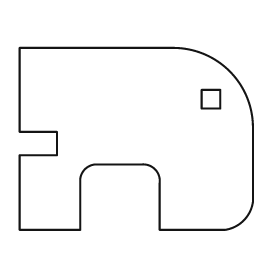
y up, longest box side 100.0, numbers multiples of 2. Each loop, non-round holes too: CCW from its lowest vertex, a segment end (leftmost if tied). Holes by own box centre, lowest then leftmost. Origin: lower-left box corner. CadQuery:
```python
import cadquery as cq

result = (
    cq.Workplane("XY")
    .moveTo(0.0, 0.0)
    .lineTo(26.0, 0.0)
    .lineTo(26.0, 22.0)
    .threePointArc((28.0, 26.0), (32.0, 28.0))
    .lineTo(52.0, 28.0)
    .threePointArc((58.0, 26.0), (60.0, 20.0))
    .lineTo(60.0, 0.0)
    .lineTo(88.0, 0.0)
    .threePointArc((96.0, 4.0), (100.0, 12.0))
    .lineTo(100.0, 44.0)
    .threePointArc((90.0, 68.0), (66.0, 78.0))
    .lineTo(0.0, 78.0)
    .lineTo(0.0, 42.0)
    .lineTo(16.0, 42.0)
    .lineTo(16.0, 32.0)
    .lineTo(0.0, 32.0)
    .close()
    .moveTo(78.0, 52.0)
    .lineTo(86.0, 52.0)
    .lineTo(86.0, 60.0)
    .lineTo(78.0, 60.0)
    .close()
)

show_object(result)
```